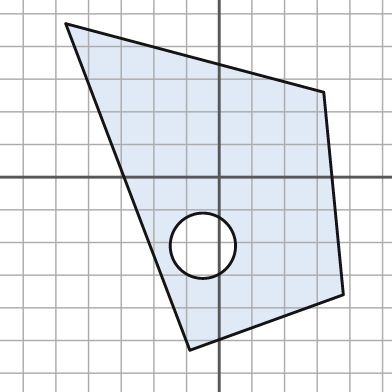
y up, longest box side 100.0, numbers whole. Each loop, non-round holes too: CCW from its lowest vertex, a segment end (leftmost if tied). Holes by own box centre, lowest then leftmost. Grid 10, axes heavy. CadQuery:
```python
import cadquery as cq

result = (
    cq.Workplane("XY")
    .moveTo(-9.0, -53.0)
    .lineTo(38.0, -36.0)
    .lineTo(32.0, 26.0)
    .lineTo(-47.0, 47.0)
    .close()
    .moveTo(-5.0, -21.0)
    .circle(10.0)
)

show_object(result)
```